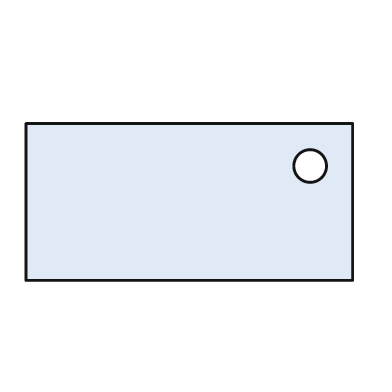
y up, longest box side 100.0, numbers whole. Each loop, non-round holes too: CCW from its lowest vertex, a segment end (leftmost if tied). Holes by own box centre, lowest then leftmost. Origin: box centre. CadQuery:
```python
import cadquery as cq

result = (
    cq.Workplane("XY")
    .moveTo(-50.0, -24.0)
    .lineTo(50.0, -24.0)
    .lineTo(50.0, 24.0)
    .lineTo(-50.0, 24.0)
    .close()
    .moveTo(37.0, 11.0)
    .circle(5.0)
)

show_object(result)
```